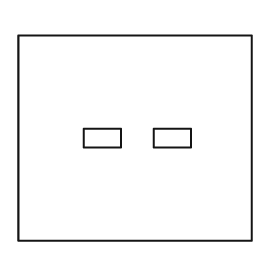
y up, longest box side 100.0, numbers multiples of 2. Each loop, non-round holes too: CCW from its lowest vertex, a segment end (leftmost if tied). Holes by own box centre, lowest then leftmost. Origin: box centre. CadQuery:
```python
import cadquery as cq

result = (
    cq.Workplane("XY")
    .moveTo(-50.0, -44.0)
    .lineTo(50.0, -44.0)
    .lineTo(50.0, 44.0)
    .lineTo(-50.0, 44.0)
    .close()
    .moveTo(-22.0, -4.0)
    .lineTo(-6.0, -4.0)
    .lineTo(-6.0, 4.0)
    .lineTo(-22.0, 4.0)
    .close()
    .moveTo(8.0, -4.0)
    .lineTo(24.0, -4.0)
    .lineTo(24.0, 4.0)
    .lineTo(8.0, 4.0)
    .close()
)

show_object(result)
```